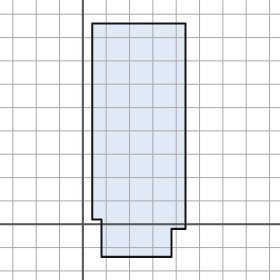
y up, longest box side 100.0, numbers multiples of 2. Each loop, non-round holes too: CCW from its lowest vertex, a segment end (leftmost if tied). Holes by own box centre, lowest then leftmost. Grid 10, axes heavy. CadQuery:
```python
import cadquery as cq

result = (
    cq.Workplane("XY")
    .moveTo(8.0, -14.0)
    .lineTo(38.0, -14.0)
    .lineTo(38.0, -2.0)
    .lineTo(44.0, -2.0)
    .lineTo(44.0, 86.0)
    .lineTo(4.0, 86.0)
    .lineTo(4.0, 2.0)
    .lineTo(8.0, 2.0)
    .close()
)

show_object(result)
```